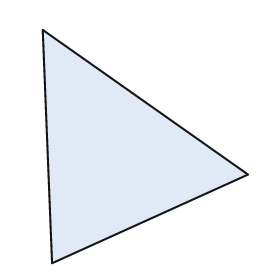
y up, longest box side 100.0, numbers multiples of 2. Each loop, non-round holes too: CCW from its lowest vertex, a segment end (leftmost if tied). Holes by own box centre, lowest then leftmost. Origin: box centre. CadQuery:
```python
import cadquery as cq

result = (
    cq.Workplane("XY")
    .moveTo(-40.0, -50.0)
    .lineTo(44.0, -12.0)
    .lineTo(-44.0, 50.0)
    .close()
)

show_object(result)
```